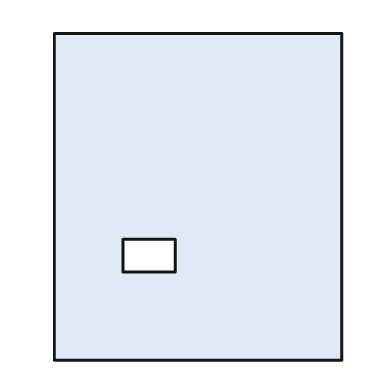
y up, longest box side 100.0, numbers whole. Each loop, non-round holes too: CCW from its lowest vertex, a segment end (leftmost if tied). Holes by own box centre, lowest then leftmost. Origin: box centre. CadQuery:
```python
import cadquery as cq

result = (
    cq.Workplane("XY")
    .moveTo(-44.0, -50.0)
    .lineTo(44.0, -50.0)
    .lineTo(44.0, 50.0)
    .lineTo(-44.0, 50.0)
    .close()
    .moveTo(-23.0, -23.0)
    .lineTo(-7.0, -23.0)
    .lineTo(-7.0, -13.0)
    .lineTo(-23.0, -13.0)
    .close()
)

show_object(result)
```